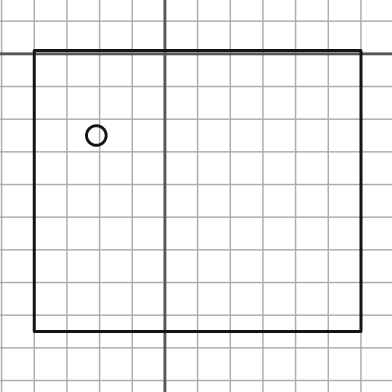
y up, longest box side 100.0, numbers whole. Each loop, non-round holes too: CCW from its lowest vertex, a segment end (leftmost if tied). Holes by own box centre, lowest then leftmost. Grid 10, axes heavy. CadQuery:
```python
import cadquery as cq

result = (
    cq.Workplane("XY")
    .moveTo(-40.0, -85.0)
    .lineTo(60.0, -85.0)
    .lineTo(60.0, 1.0)
    .lineTo(-40.0, 1.0)
    .close()
    .moveTo(-21.0, -25.0)
    .circle(3.0)
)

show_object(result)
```